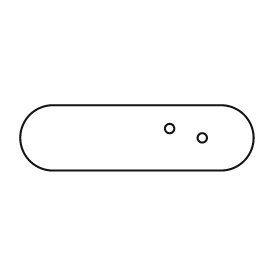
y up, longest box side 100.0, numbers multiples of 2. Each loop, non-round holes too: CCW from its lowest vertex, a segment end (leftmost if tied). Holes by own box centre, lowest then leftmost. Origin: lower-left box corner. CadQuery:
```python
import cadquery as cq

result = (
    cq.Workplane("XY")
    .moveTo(14.0, 0.0)
    .lineTo(86.0, 0.0)
    .threePointArc((100.0, 14.0), (86.0, 28.0))
    .lineTo(14.0, 28.0)
    .threePointArc((0.0, 14.0), (14.0, 0.0))
    .close()
    .moveTo(78.0, 14.0)
    .circle(2.0)
    .moveTo(64.0, 18.0)
    .circle(2.0)
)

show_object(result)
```